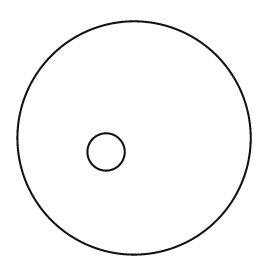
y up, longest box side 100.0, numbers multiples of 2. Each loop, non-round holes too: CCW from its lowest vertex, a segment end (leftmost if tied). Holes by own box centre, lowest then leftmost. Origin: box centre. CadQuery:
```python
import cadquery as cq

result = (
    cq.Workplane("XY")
    .moveTo(0.0, 0.0)
    .circle(50.0)
    .moveTo(-12.0, -6.0)
    .circle(8.0)
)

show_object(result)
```